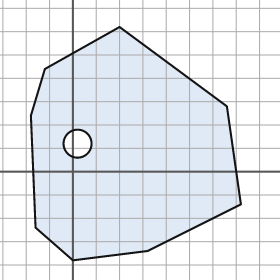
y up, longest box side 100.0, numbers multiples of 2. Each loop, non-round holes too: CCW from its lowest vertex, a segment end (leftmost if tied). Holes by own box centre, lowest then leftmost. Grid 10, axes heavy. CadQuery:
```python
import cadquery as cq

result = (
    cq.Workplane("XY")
    .moveTo(0.0, -38.0)
    .lineTo(32.0, -34.0)
    .lineTo(72.0, -14.0)
    .lineTo(66.0, 28.0)
    .lineTo(20.0, 62.0)
    .lineTo(-12.0, 44.0)
    .lineTo(-18.0, 24.0)
    .lineTo(-16.0, -24.0)
    .close()
    .moveTo(2.0, 12.0)
    .circle(6.0)
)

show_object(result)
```